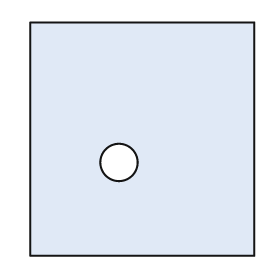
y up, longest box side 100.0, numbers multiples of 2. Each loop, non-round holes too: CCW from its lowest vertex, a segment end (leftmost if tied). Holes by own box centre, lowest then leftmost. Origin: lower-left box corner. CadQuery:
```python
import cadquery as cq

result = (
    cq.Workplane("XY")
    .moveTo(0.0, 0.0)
    .lineTo(96.0, 0.0)
    .lineTo(96.0, 100.0)
    .lineTo(0.0, 100.0)
    .close()
    .moveTo(38.0, 40.0)
    .circle(8.0)
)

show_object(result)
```